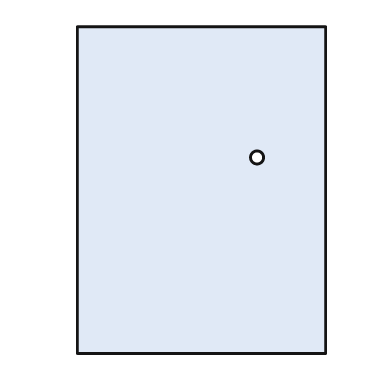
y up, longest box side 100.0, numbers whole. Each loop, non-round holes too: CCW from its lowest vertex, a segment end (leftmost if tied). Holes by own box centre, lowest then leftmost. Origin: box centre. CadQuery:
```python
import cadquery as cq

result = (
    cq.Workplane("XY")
    .moveTo(-38.0, -50.0)
    .lineTo(38.0, -50.0)
    .lineTo(38.0, 50.0)
    .lineTo(-38.0, 50.0)
    .close()
    .moveTo(17.0, 10.0)
    .circle(2.0)
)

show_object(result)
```